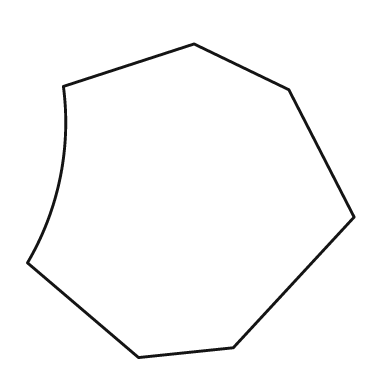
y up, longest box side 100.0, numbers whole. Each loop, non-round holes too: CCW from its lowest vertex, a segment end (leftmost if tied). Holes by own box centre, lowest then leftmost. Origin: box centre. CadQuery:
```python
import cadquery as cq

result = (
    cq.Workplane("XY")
    .moveTo(-16.0, -48.0)
    .lineTo(13.0, -45.0)
    .lineTo(50.0, -5.0)
    .lineTo(30.0, 34.0)
    .lineTo(1.0, 48.0)
    .lineTo(-39.0, 35.0)
    .threePointArc((-40.0, 7.0), (-50.0, -19.0))
    .close()
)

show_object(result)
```